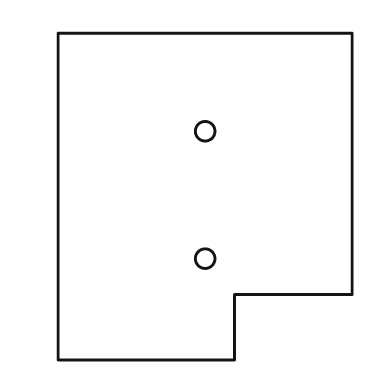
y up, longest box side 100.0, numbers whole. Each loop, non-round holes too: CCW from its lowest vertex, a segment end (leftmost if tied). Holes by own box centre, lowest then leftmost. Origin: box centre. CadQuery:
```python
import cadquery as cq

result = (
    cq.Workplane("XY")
    .moveTo(-45.0, -50.0)
    .lineTo(9.0, -50.0)
    .lineTo(9.0, -30.0)
    .lineTo(45.0, -30.0)
    .lineTo(45.0, 50.0)
    .lineTo(-45.0, 50.0)
    .close()
    .moveTo(0.0, -19.0)
    .circle(3.0)
    .moveTo(0.0, 20.0)
    .circle(3.0)
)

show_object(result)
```